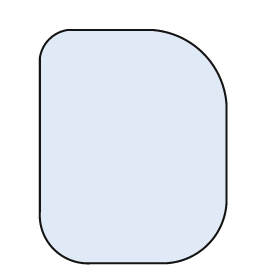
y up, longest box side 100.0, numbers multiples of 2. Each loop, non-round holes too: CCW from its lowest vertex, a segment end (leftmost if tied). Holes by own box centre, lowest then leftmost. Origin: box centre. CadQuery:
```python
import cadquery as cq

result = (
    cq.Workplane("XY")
    .moveTo(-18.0, -50.0)
    .lineTo(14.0, -50.0)
    .threePointArc((32.0, -42.0), (40.0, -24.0))
    .lineTo(40.0, 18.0)
    .threePointArc((30.0, 40.0), (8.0, 50.0))
    .lineTo(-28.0, 50.0)
    .threePointArc((-36.0, 46.0), (-40.0, 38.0))
    .lineTo(-40.0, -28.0)
    .threePointArc((-34.0, -44.0), (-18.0, -50.0))
    .close()
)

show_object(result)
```